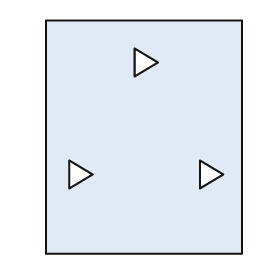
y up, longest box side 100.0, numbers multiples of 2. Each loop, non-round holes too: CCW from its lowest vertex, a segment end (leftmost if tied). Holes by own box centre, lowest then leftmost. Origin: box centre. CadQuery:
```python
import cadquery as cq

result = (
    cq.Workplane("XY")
    .moveTo(-42.0, -50.0)
    .lineTo(42.0, -50.0)
    .lineTo(42.0, 50.0)
    .lineTo(-42.0, 50.0)
    .close()
    .moveTo(-32.0, -22.0)
    .lineTo(-22.0, -16.0)
    .lineTo(-32.0, -10.0)
    .close()
    .moveTo(24.0, -22.0)
    .lineTo(34.0, -16.0)
    .lineTo(24.0, -10.0)
    .close()
    .moveTo(-4.0, 26.0)
    .lineTo(6.0, 32.0)
    .lineTo(-4.0, 38.0)
    .close()
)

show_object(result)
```